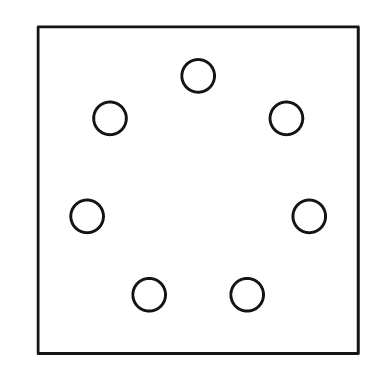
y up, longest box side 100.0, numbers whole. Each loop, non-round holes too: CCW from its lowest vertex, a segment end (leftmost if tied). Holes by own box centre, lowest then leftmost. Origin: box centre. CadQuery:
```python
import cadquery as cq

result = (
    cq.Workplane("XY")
    .moveTo(-49.0, -50.0)
    .lineTo(49.0, -50.0)
    .lineTo(49.0, 50.0)
    .lineTo(-49.0, 50.0)
    .close()
    .moveTo(-15.0, -32.0)
    .circle(5.0)
    .moveTo(15.0, -32.0)
    .circle(5.0)
    .moveTo(-34.0, -8.0)
    .circle(5.0)
    .moveTo(34.0, -8.0)
    .circle(5.0)
    .moveTo(-27.0, 22.0)
    .circle(5.0)
    .moveTo(27.0, 22.0)
    .circle(5.0)
    .moveTo(0.0, 35.0)
    .circle(5.0)
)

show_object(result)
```